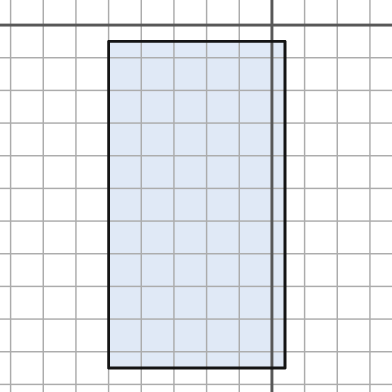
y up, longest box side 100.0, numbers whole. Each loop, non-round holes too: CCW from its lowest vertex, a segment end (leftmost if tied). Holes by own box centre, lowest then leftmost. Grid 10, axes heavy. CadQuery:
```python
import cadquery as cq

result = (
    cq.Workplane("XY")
    .moveTo(-50.0, -105.0)
    .lineTo(4.0, -105.0)
    .lineTo(4.0, -5.0)
    .lineTo(-50.0, -5.0)
    .close()
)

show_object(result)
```